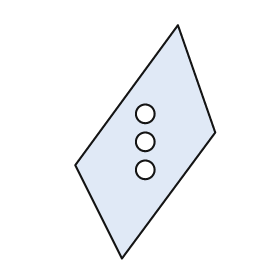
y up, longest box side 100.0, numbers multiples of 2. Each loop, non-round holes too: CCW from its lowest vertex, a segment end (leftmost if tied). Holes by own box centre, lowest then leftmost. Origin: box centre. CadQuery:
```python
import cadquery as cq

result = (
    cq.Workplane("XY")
    .moveTo(-10.0, -50.0)
    .lineTo(30.0, 4.0)
    .lineTo(14.0, 50.0)
    .lineTo(-30.0, -10.0)
    .close()
    .moveTo(0.0, -12.0)
    .circle(4.0)
    .moveTo(0.0, 0.0)
    .circle(4.0)
    .moveTo(0.0, 12.0)
    .circle(4.0)
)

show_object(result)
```